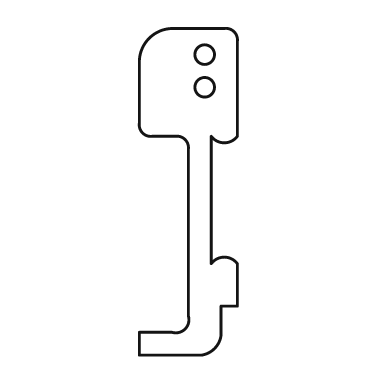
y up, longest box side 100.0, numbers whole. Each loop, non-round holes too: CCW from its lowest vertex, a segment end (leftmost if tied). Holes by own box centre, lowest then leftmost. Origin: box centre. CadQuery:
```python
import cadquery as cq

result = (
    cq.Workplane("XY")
    .moveTo(-15.0, -50.0)
    .lineTo(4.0, -50.0)
    .threePointArc((8.0, -48.0), (10.0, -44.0))
    .lineTo(10.0, -35.0)
    .lineTo(15.0, -35.0)
    .lineTo(15.0, -22.0)
    .threePointArc((11.0, -20.0), (7.0, -22.0))
    .lineTo(7.0, 17.0)
    .threePointArc((11.0, 15.0), (15.0, 17.0))
    .lineTo(15.0, 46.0)
    .threePointArc((14.0, 49.0), (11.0, 50.0))
    .lineTo(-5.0, 50.0)
    .threePointArc((-12.0, 47.0), (-15.0, 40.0))
    .lineTo(-15.0, 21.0)
    .threePointArc((-14.0, 18.0), (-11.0, 17.0))
    .lineTo(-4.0, 17.0)
    .threePointArc((-1.0, 16.0), (0.0, 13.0))
    .lineTo(0.0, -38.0)
    .threePointArc((-1.0, -42.0), (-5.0, -43.0))
    .lineTo(-15.0, -43.0)
    .close()
    .moveTo(5.0, 32.0)
    .circle(3.0)
    .moveTo(5.0, 42.0)
    .circle(3.0)
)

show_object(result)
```